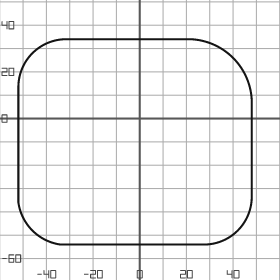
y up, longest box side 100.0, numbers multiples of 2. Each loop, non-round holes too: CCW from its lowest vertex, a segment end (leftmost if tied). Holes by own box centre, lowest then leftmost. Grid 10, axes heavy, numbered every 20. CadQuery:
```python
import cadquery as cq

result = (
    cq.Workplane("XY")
    .moveTo(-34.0, -54.0)
    .lineTo(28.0, -54.0)
    .threePointArc((42.0, -48.0), (48.0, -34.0))
    .lineTo(48.0, 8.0)
    .threePointArc((40.0, 26.0), (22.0, 34.0))
    .lineTo(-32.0, 34.0)
    .threePointArc((-46.0, 28.0), (-52.0, 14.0))
    .lineTo(-52.0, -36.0)
    .threePointArc((-46.0, -48.0), (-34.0, -54.0))
    .close()
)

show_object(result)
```